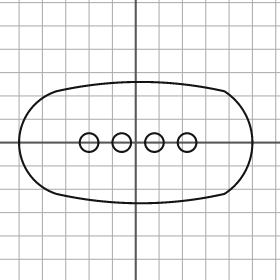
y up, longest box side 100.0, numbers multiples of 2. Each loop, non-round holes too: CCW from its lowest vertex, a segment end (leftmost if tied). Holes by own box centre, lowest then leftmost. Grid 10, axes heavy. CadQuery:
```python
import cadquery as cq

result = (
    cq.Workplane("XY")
    .moveTo(-34.0, -22.0)
    .threePointArc((2.0, -26.0), (38.0, -22.0))
    .threePointArc((50.0, 0.0), (38.0, 22.0))
    .threePointArc((2.0, 26.0), (-34.0, 22.0))
    .threePointArc((-50.0, 0.0), (-34.0, -22.0))
    .close()
    .moveTo(-20.0, 0.0)
    .circle(4.0)
    .moveTo(-6.0, 0.0)
    .circle(4.0)
    .moveTo(8.0, 0.0)
    .circle(4.0)
    .moveTo(22.0, 0.0)
    .circle(4.0)
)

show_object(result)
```